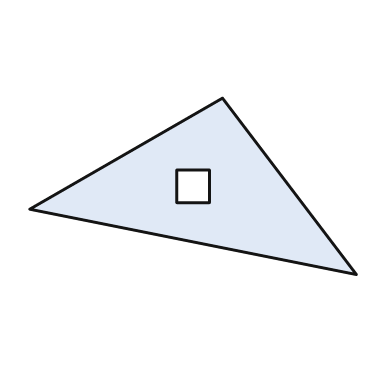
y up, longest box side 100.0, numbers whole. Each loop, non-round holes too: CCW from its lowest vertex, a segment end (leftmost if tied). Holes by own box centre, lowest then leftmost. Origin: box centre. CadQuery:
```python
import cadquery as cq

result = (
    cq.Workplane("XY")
    .moveTo(50.0, -27.0)
    .lineTo(9.0, 27.0)
    .lineTo(-50.0, -7.0)
    .close()
    .moveTo(-5.0, -5.0)
    .lineTo(5.0, -5.0)
    .lineTo(5.0, 5.0)
    .lineTo(-5.0, 5.0)
    .close()
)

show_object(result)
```